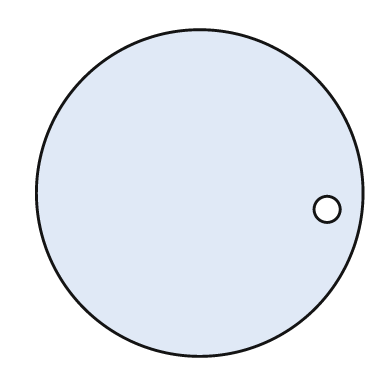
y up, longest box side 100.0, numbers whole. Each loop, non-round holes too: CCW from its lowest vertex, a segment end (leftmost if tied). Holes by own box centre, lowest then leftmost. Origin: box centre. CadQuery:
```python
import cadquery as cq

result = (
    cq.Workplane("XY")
    .moveTo(0.0, 0.0)
    .circle(50.0)
    .moveTo(39.0, -5.0)
    .circle(4.0)
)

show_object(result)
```